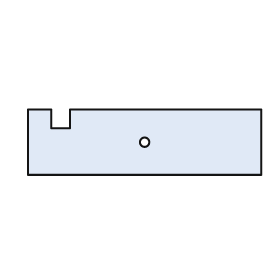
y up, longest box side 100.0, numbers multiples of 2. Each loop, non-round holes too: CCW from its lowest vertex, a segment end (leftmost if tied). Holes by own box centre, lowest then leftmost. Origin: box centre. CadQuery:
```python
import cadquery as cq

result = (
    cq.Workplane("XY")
    .moveTo(-50.0, -14.0)
    .lineTo(50.0, -14.0)
    .lineTo(50.0, 14.0)
    .lineTo(-32.0, 14.0)
    .lineTo(-32.0, 6.0)
    .lineTo(-40.0, 6.0)
    .lineTo(-40.0, 14.0)
    .lineTo(-50.0, 14.0)
    .close()
    .moveTo(0.0, 0.0)
    .circle(2.0)
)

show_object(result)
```